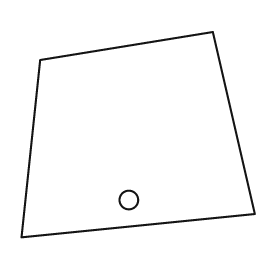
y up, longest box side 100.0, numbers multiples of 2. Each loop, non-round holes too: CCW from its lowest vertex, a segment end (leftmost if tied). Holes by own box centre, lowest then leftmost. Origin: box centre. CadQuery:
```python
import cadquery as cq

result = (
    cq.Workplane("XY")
    .moveTo(-50.0, -44.0)
    .lineTo(50.0, -34.0)
    .lineTo(32.0, 44.0)
    .lineTo(-42.0, 32.0)
    .close()
    .moveTo(-4.0, -28.0)
    .circle(4.0)
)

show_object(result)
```